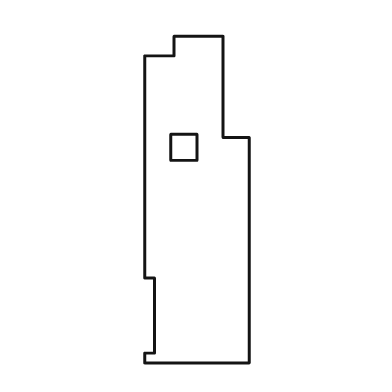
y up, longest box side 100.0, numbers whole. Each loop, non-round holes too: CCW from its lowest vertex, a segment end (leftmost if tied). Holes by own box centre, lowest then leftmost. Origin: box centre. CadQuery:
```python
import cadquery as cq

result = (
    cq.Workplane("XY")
    .moveTo(-16.0, -50.0)
    .lineTo(16.0, -50.0)
    .lineTo(16.0, 19.0)
    .lineTo(8.0, 19.0)
    .lineTo(8.0, 50.0)
    .lineTo(-7.0, 50.0)
    .lineTo(-7.0, 44.0)
    .lineTo(-16.0, 44.0)
    .lineTo(-16.0, -24.0)
    .lineTo(-13.0, -24.0)
    .lineTo(-13.0, -47.0)
    .lineTo(-16.0, -47.0)
    .close()
    .moveTo(-8.0, 12.0)
    .lineTo(0.0, 12.0)
    .lineTo(0.0, 20.0)
    .lineTo(-8.0, 20.0)
    .close()
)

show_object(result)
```